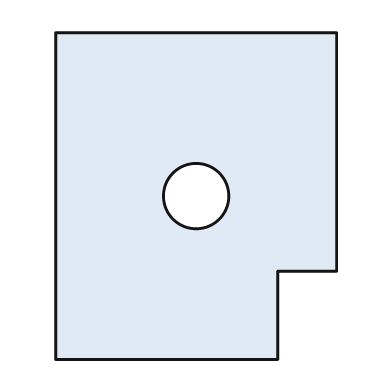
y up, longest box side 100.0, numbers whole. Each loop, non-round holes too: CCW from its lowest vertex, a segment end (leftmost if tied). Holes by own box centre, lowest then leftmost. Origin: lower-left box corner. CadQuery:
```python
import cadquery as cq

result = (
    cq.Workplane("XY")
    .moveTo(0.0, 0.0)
    .lineTo(68.0, 0.0)
    .lineTo(68.0, 27.0)
    .lineTo(86.0, 27.0)
    .lineTo(86.0, 100.0)
    .lineTo(0.0, 100.0)
    .close()
    .moveTo(43.0, 50.0)
    .circle(10.0)
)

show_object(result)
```